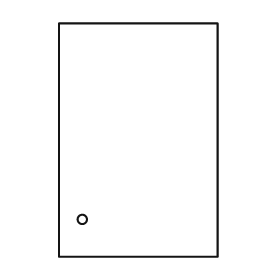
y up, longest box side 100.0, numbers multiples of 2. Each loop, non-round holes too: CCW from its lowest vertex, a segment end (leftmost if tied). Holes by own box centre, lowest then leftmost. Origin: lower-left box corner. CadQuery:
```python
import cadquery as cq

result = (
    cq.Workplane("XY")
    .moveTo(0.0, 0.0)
    .lineTo(68.0, 0.0)
    .lineTo(68.0, 100.0)
    .lineTo(0.0, 100.0)
    .close()
    .moveTo(10.0, 16.0)
    .circle(2.0)
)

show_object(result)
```